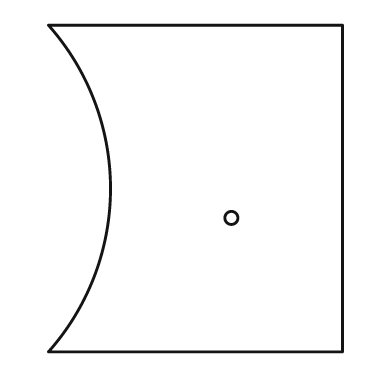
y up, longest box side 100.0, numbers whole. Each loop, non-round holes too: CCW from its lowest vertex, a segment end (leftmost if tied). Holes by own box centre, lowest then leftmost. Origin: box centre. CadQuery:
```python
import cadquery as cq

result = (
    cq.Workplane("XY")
    .moveTo(-45.0, -50.0)
    .lineTo(45.0, -50.0)
    .lineTo(45.0, 50.0)
    .lineTo(-45.0, 50.0)
    .threePointArc((-26.0, 0.0), (-45.0, -50.0))
    .close()
    .moveTo(11.0, -9.0)
    .circle(2.0)
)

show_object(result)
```